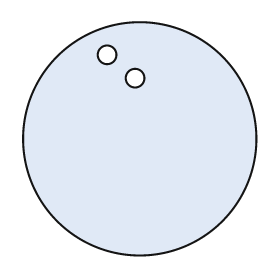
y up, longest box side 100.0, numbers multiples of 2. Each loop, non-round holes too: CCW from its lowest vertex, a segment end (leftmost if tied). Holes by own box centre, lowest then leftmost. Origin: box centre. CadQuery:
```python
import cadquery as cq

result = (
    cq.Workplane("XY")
    .moveTo(0.0, 0.0)
    .circle(50.0)
    .moveTo(-2.0, 26.0)
    .circle(4.0)
    .moveTo(-14.0, 36.0)
    .circle(4.0)
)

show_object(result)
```